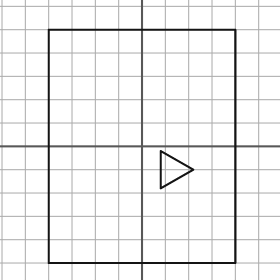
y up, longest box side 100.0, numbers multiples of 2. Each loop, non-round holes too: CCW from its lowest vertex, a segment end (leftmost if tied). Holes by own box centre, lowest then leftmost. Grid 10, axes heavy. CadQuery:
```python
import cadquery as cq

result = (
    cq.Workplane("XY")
    .moveTo(-40.0, -50.0)
    .lineTo(40.0, -50.0)
    .lineTo(40.0, 50.0)
    .lineTo(-40.0, 50.0)
    .close()
    .moveTo(8.0, -18.0)
    .lineTo(22.0, -10.0)
    .lineTo(8.0, -2.0)
    .close()
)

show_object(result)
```